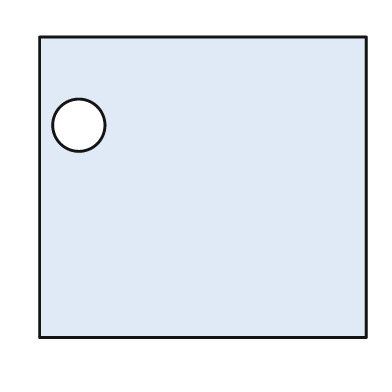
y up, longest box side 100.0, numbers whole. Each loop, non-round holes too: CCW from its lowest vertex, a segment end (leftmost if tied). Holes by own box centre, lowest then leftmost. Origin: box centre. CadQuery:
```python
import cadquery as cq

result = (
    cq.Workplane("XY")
    .moveTo(-50.0, -46.0)
    .lineTo(50.0, -46.0)
    .lineTo(50.0, 46.0)
    .lineTo(-50.0, 46.0)
    .close()
    .moveTo(-38.0, 19.0)
    .circle(8.0)
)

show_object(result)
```